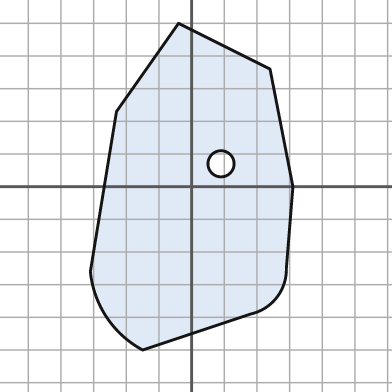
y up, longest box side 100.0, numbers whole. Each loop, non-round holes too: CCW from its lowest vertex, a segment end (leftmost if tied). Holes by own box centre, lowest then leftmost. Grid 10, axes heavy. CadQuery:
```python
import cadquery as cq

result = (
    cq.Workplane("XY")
    .moveTo(-15.0, -50.0)
    .lineTo(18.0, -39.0)
    .threePointArc((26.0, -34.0), (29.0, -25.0))
    .lineTo(31.0, 0.0)
    .lineTo(24.0, 36.0)
    .lineTo(-4.0, 50.0)
    .lineTo(-23.0, 23.0)
    .lineTo(-31.0, -26.0)
    .threePointArc((-26.0, -40.0), (-15.0, -50.0))
    .close()
    .moveTo(9.0, 7.0)
    .circle(4.0)
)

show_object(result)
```